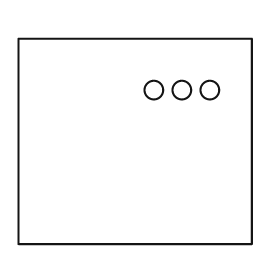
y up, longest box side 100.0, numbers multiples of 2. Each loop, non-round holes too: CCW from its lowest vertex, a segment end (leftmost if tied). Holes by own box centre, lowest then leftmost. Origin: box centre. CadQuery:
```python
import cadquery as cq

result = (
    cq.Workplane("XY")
    .moveTo(-50.0, -44.0)
    .lineTo(50.0, -44.0)
    .lineTo(50.0, 44.0)
    .lineTo(-50.0, 44.0)
    .close()
    .moveTo(8.0, 22.0)
    .circle(4.0)
    .moveTo(20.0, 22.0)
    .circle(4.0)
    .moveTo(32.0, 22.0)
    .circle(4.0)
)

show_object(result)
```